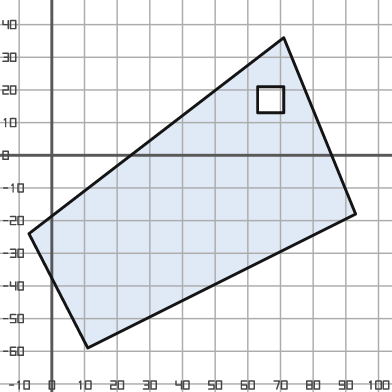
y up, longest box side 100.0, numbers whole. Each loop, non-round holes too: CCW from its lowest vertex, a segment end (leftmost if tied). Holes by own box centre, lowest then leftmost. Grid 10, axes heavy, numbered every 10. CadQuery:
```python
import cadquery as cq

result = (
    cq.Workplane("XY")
    .moveTo(11.0, -59.0)
    .lineTo(93.0, -18.0)
    .lineTo(71.0, 36.0)
    .lineTo(-7.0, -24.0)
    .close()
    .moveTo(63.0, 13.0)
    .lineTo(71.0, 13.0)
    .lineTo(71.0, 21.0)
    .lineTo(63.0, 21.0)
    .close()
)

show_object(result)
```